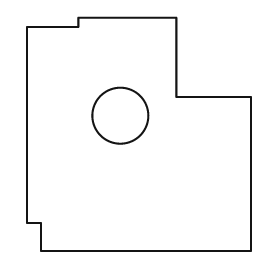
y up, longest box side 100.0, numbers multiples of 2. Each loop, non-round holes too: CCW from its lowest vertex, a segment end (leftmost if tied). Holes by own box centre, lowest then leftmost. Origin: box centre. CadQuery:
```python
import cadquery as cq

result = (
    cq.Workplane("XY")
    .moveTo(-42.0, -50.0)
    .lineTo(48.0, -50.0)
    .lineTo(48.0, 16.0)
    .lineTo(16.0, 16.0)
    .lineTo(16.0, 50.0)
    .lineTo(-26.0, 50.0)
    .lineTo(-26.0, 46.0)
    .lineTo(-48.0, 46.0)
    .lineTo(-48.0, -38.0)
    .lineTo(-42.0, -38.0)
    .close()
    .moveTo(-8.0, 8.0)
    .circle(12.0)
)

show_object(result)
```